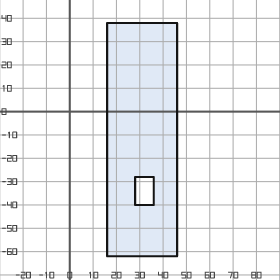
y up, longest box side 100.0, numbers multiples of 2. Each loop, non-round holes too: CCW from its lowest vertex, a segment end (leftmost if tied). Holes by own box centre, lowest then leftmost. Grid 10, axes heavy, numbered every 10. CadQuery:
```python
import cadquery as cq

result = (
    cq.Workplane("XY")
    .moveTo(16.0, -62.0)
    .lineTo(46.0, -62.0)
    .lineTo(46.0, 38.0)
    .lineTo(16.0, 38.0)
    .close()
    .moveTo(28.0, -40.0)
    .lineTo(36.0, -40.0)
    .lineTo(36.0, -28.0)
    .lineTo(28.0, -28.0)
    .close()
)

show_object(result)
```